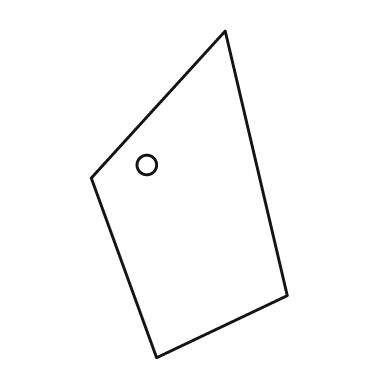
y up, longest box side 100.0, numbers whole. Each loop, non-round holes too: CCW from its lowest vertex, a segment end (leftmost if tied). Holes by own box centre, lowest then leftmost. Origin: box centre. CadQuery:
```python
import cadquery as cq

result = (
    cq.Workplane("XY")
    .moveTo(-10.0, -50.0)
    .lineTo(30.0, -31.0)
    .lineTo(11.0, 50.0)
    .lineTo(-30.0, 5.0)
    .close()
    .moveTo(-13.0, 9.0)
    .circle(3.0)
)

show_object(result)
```